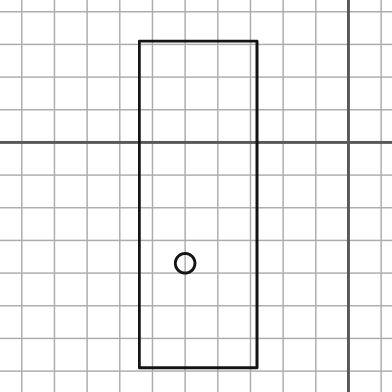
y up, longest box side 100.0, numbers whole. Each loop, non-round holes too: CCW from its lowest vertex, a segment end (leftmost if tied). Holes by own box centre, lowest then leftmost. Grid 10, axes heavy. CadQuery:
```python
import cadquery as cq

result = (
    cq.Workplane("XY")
    .moveTo(-64.0, -69.0)
    .lineTo(-28.0, -69.0)
    .lineTo(-28.0, 31.0)
    .lineTo(-64.0, 31.0)
    .close()
    .moveTo(-50.0, -37.0)
    .circle(3.0)
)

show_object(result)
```